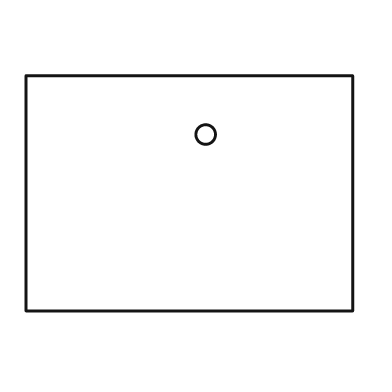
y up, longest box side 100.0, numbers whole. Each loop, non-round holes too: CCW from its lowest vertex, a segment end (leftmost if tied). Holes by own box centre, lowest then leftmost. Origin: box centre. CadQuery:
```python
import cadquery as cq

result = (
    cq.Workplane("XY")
    .moveTo(-50.0, -36.0)
    .lineTo(50.0, -36.0)
    .lineTo(50.0, 36.0)
    .lineTo(-50.0, 36.0)
    .close()
    .moveTo(5.0, 18.0)
    .circle(3.0)
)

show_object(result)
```